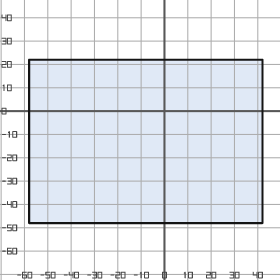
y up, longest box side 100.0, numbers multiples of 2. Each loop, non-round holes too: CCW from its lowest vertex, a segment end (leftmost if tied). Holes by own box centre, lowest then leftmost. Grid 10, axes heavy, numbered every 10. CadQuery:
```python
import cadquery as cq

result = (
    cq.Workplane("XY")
    .moveTo(-58.0, -48.0)
    .lineTo(42.0, -48.0)
    .lineTo(42.0, 22.0)
    .lineTo(-58.0, 22.0)
    .close()
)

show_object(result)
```